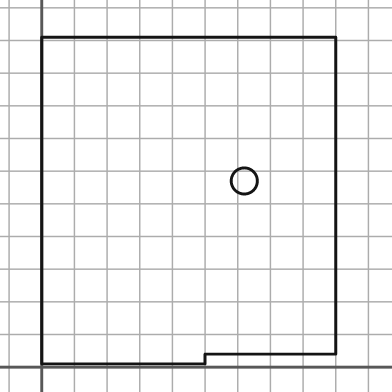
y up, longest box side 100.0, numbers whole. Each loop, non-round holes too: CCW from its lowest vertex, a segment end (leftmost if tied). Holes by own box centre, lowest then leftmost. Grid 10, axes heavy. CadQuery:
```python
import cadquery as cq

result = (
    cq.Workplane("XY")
    .moveTo(0.0, 1.0)
    .lineTo(50.0, 1.0)
    .lineTo(50.0, 4.0)
    .lineTo(90.0, 4.0)
    .lineTo(90.0, 101.0)
    .lineTo(0.0, 101.0)
    .close()
    .moveTo(62.0, 57.0)
    .circle(4.0)
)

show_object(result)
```